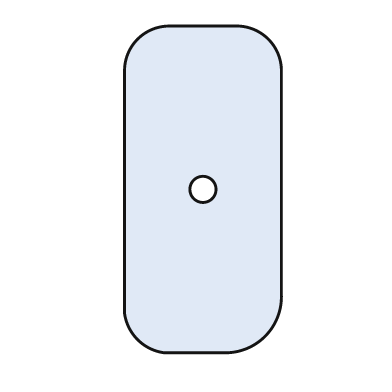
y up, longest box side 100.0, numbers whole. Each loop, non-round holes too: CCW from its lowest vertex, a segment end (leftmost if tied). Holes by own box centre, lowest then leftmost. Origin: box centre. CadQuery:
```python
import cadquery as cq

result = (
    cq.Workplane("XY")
    .moveTo(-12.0, -50.0)
    .lineTo(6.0, -50.0)
    .threePointArc((19.0, -45.0), (24.0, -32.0))
    .lineTo(24.0, 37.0)
    .threePointArc((20.0, 46.0), (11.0, 50.0))
    .lineTo(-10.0, 50.0)
    .threePointArc((-20.0, 46.0), (-24.0, 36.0))
    .lineTo(-24.0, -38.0)
    .threePointArc((-20.0, -46.0), (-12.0, -50.0))
    .close()
    .moveTo(0.0, 0.0)
    .circle(4.0)
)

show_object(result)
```